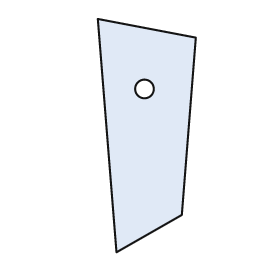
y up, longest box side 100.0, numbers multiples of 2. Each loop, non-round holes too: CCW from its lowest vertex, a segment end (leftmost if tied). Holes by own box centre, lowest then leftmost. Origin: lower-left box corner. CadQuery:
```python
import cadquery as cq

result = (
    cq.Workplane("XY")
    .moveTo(8.0, 0.0)
    .lineTo(36.0, 16.0)
    .lineTo(42.0, 92.0)
    .lineTo(0.0, 100.0)
    .close()
    .moveTo(20.0, 70.0)
    .circle(4.0)
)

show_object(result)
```